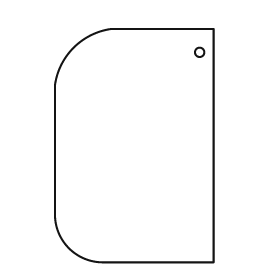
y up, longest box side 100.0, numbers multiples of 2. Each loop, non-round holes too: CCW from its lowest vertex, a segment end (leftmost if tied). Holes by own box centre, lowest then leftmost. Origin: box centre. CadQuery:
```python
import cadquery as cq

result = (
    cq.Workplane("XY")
    .moveTo(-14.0, -50.0)
    .lineTo(34.0, -50.0)
    .lineTo(34.0, 50.0)
    .lineTo(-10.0, 50.0)
    .threePointArc((-26.0, 42.0), (-34.0, 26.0))
    .lineTo(-34.0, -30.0)
    .threePointArc((-28.0, -44.0), (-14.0, -50.0))
    .close()
    .moveTo(28.0, 40.0)
    .circle(2.0)
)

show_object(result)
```